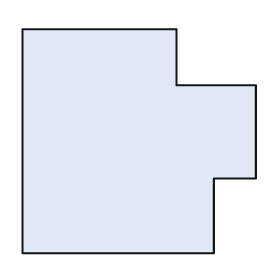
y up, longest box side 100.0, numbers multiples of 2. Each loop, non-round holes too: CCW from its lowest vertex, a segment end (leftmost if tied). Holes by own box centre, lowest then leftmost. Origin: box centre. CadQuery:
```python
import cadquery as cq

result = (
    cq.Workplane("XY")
    .moveTo(-50.0, -48.0)
    .lineTo(32.0, -48.0)
    .lineTo(32.0, -16.0)
    .lineTo(50.0, -16.0)
    .lineTo(50.0, 24.0)
    .lineTo(16.0, 24.0)
    .lineTo(16.0, 48.0)
    .lineTo(-50.0, 48.0)
    .close()
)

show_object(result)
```